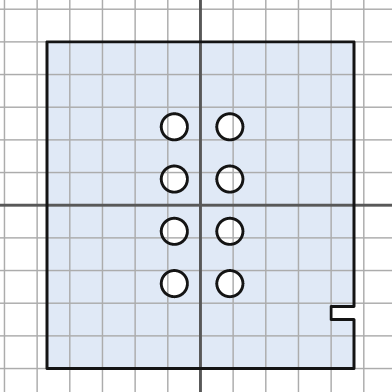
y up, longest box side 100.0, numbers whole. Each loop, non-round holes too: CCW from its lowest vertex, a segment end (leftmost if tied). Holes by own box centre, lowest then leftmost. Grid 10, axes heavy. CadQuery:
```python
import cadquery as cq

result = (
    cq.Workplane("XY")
    .moveTo(-47.0, -50.0)
    .lineTo(47.0, -50.0)
    .lineTo(47.0, -35.0)
    .lineTo(40.0, -35.0)
    .lineTo(40.0, -31.0)
    .lineTo(47.0, -31.0)
    .lineTo(47.0, 50.0)
    .lineTo(-47.0, 50.0)
    .close()
    .moveTo(-8.0, -24.0)
    .circle(4.0)
    .moveTo(9.0, -24.0)
    .circle(4.0)
    .moveTo(-8.0, -8.0)
    .circle(4.0)
    .moveTo(9.0, -8.0)
    .circle(4.0)
    .moveTo(-8.0, 8.0)
    .circle(4.0)
    .moveTo(9.0, 8.0)
    .circle(4.0)
    .moveTo(-8.0, 24.0)
    .circle(4.0)
    .moveTo(9.0, 24.0)
    .circle(4.0)
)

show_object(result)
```